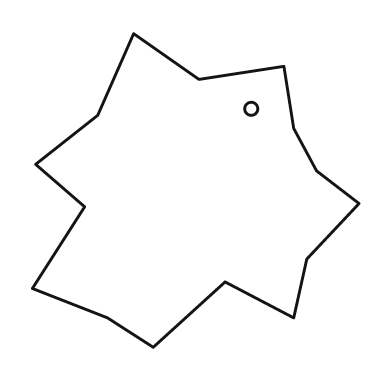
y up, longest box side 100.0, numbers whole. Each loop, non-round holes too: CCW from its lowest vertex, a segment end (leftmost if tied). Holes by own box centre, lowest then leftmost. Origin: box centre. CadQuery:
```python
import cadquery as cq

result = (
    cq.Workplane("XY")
    .moveTo(-13.0, -48.0)
    .lineTo(9.0, -28.0)
    .lineTo(30.0, -39.0)
    .lineTo(34.0, -21.0)
    .lineTo(50.0, -4.0)
    .lineTo(37.0, 6.0)
    .lineTo(30.0, 19.0)
    .lineTo(27.0, 38.0)
    .lineTo(1.0, 34.0)
    .lineTo(-19.0, 48.0)
    .lineTo(-30.0, 23.0)
    .lineTo(-49.0, 8.0)
    .lineTo(-34.0, -5.0)
    .lineTo(-50.0, -30.0)
    .lineTo(-27.0, -39.0)
    .close()
    .moveTo(17.0, 25.0)
    .circle(2.0)
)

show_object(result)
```